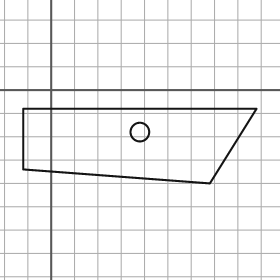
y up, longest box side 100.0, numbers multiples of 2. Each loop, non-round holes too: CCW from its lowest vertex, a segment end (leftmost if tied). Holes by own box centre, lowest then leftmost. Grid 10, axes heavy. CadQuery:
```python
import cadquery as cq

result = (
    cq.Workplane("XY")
    .moveTo(68.0, -40.0)
    .lineTo(88.0, -8.0)
    .lineTo(-12.0, -8.0)
    .lineTo(-12.0, -34.0)
    .close()
    .moveTo(38.0, -18.0)
    .circle(4.0)
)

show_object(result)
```